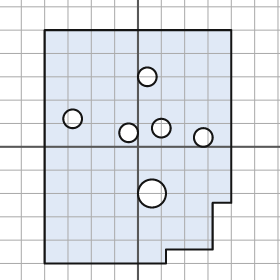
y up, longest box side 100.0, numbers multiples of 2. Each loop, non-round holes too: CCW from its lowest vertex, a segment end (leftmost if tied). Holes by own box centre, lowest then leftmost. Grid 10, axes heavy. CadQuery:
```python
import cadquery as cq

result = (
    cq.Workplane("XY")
    .moveTo(-40.0, -50.0)
    .lineTo(12.0, -50.0)
    .lineTo(12.0, -44.0)
    .lineTo(32.0, -44.0)
    .lineTo(32.0, -24.0)
    .lineTo(40.0, -24.0)
    .lineTo(40.0, 50.0)
    .lineTo(-40.0, 50.0)
    .close()
    .moveTo(6.0, -20.0)
    .circle(6.0)
    .moveTo(28.0, 4.0)
    .circle(4.0)
    .moveTo(-4.0, 6.0)
    .circle(4.0)
    .moveTo(10.0, 8.0)
    .circle(4.0)
    .moveTo(-28.0, 12.0)
    .circle(4.0)
    .moveTo(4.0, 30.0)
    .circle(4.0)
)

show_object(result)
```